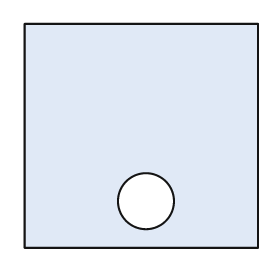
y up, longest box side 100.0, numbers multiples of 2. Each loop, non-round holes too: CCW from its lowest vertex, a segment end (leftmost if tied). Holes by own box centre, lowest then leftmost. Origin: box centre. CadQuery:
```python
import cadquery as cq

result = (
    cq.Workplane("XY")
    .moveTo(-50.0, -48.0)
    .lineTo(50.0, -48.0)
    .lineTo(50.0, 48.0)
    .lineTo(-50.0, 48.0)
    .close()
    .moveTo(2.0, -28.0)
    .circle(12.0)
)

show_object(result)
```